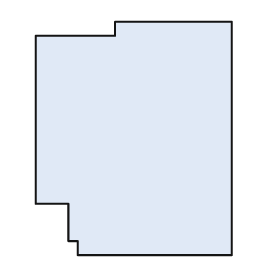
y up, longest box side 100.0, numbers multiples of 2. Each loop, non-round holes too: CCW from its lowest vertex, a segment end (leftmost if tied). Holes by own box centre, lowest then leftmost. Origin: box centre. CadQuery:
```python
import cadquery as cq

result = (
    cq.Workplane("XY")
    .moveTo(-24.0, -50.0)
    .lineTo(42.0, -50.0)
    .lineTo(42.0, 50.0)
    .lineTo(-8.0, 50.0)
    .lineTo(-8.0, 44.0)
    .lineTo(-42.0, 44.0)
    .lineTo(-42.0, -28.0)
    .lineTo(-28.0, -28.0)
    .lineTo(-28.0, -44.0)
    .lineTo(-24.0, -44.0)
    .close()
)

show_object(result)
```